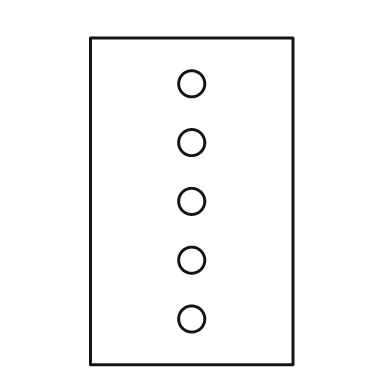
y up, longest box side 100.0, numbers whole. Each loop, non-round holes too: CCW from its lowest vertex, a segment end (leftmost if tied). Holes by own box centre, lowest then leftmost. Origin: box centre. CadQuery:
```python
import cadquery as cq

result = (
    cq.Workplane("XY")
    .moveTo(-31.0, -50.0)
    .lineTo(31.0, -50.0)
    .lineTo(31.0, 50.0)
    .lineTo(-31.0, 50.0)
    .close()
    .moveTo(0.0, -36.0)
    .circle(4.0)
    .moveTo(0.0, -18.0)
    .circle(4.0)
    .moveTo(0.0, 0.0)
    .circle(4.0)
    .moveTo(0.0, 18.0)
    .circle(4.0)
    .moveTo(0.0, 36.0)
    .circle(4.0)
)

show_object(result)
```